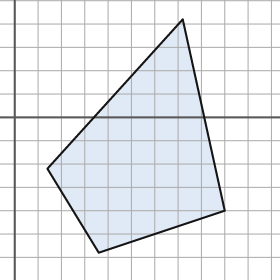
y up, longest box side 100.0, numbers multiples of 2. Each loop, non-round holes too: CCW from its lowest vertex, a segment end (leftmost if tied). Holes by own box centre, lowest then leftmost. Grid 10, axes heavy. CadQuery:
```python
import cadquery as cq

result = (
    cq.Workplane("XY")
    .moveTo(36.0, -58.0)
    .lineTo(90.0, -40.0)
    .lineTo(72.0, 42.0)
    .lineTo(14.0, -22.0)
    .close()
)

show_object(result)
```